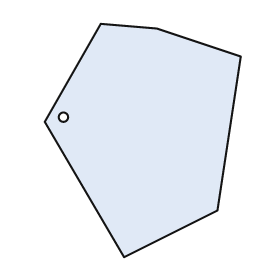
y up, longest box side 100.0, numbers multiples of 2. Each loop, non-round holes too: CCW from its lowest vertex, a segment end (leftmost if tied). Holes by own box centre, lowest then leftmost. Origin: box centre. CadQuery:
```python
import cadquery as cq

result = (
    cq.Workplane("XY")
    .moveTo(-8.0, -50.0)
    .lineTo(32.0, -30.0)
    .lineTo(42.0, 36.0)
    .lineTo(6.0, 48.0)
    .lineTo(-18.0, 50.0)
    .lineTo(-42.0, 8.0)
    .close()
    .moveTo(-34.0, 10.0)
    .circle(2.0)
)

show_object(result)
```